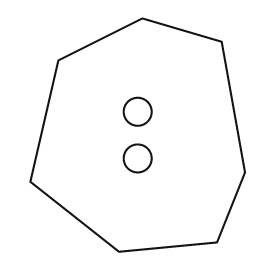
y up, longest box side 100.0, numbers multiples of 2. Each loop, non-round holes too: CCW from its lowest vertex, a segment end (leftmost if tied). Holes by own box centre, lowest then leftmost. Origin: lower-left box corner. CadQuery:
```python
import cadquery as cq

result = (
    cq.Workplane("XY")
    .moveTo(38.0, 0.0)
    .lineTo(80.0, 4.0)
    .lineTo(92.0, 34.0)
    .lineTo(82.0, 90.0)
    .lineTo(48.0, 100.0)
    .lineTo(12.0, 82.0)
    .lineTo(0.0, 30.0)
    .close()
    .moveTo(46.0, 40.0)
    .circle(6.0)
    .moveTo(46.0, 60.0)
    .circle(6.0)
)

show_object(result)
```